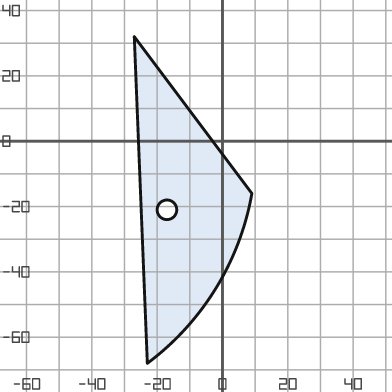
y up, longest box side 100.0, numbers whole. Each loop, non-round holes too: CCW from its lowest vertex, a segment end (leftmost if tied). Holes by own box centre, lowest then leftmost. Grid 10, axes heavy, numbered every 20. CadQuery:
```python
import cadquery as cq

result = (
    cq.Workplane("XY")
    .moveTo(-23.0, -68.0)
    .threePointArc((-2.0, -45.0), (9.0, -16.0))
    .lineTo(-27.0, 32.0)
    .close()
    .moveTo(-17.0, -21.0)
    .circle(3.0)
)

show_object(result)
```